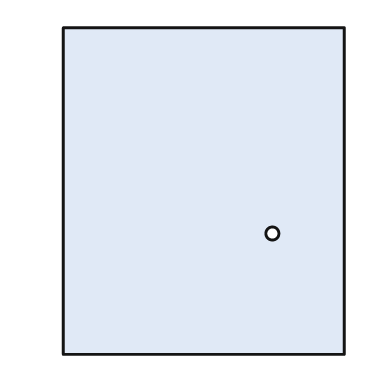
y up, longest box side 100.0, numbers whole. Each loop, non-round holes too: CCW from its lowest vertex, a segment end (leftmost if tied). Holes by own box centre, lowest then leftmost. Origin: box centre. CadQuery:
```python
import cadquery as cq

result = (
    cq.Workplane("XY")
    .moveTo(-43.0, -50.0)
    .lineTo(43.0, -50.0)
    .lineTo(43.0, 50.0)
    .lineTo(-43.0, 50.0)
    .close()
    .moveTo(21.0, -13.0)
    .circle(2.0)
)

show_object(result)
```